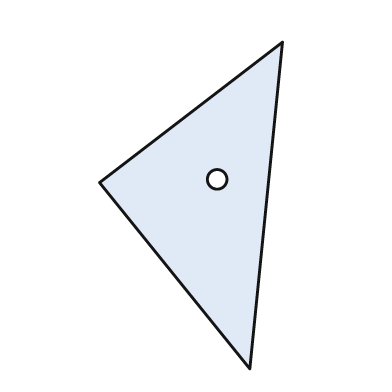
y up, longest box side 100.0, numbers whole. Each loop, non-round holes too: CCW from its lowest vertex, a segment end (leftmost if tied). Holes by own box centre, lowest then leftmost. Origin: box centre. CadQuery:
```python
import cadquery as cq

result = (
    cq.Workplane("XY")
    .moveTo(18.0, -50.0)
    .lineTo(28.0, 50.0)
    .lineTo(-28.0, 7.0)
    .close()
    .moveTo(8.0, 8.0)
    .circle(3.0)
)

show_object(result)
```